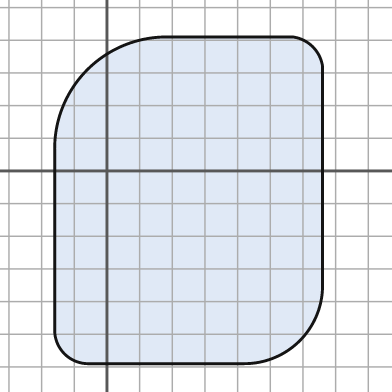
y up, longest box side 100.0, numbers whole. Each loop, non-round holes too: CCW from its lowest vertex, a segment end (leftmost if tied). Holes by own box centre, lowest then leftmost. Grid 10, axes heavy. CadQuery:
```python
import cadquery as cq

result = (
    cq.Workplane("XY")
    .moveTo(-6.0, -59.0)
    .lineTo(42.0, -59.0)
    .threePointArc((59.0, -52.0), (66.0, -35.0))
    .lineTo(66.0, 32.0)
    .threePointArc((63.0, 38.0), (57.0, 41.0))
    .lineTo(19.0, 41.0)
    .threePointArc((-6.0, 31.0), (-16.0, 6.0))
    .lineTo(-16.0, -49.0)
    .threePointArc((-13.0, -56.0), (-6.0, -59.0))
    .close()
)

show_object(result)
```